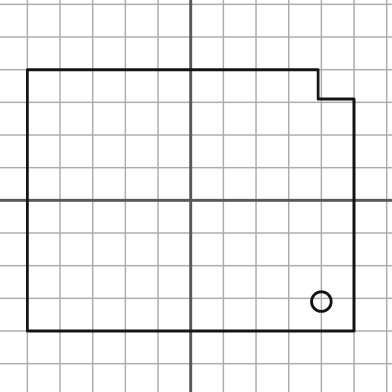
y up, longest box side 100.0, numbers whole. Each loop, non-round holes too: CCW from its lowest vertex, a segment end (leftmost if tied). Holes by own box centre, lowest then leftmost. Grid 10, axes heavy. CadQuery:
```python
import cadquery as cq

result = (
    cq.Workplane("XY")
    .moveTo(-50.0, -40.0)
    .lineTo(50.0, -40.0)
    .lineTo(50.0, 31.0)
    .lineTo(39.0, 31.0)
    .lineTo(39.0, 40.0)
    .lineTo(-50.0, 40.0)
    .close()
    .moveTo(40.0, -31.0)
    .circle(3.0)
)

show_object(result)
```